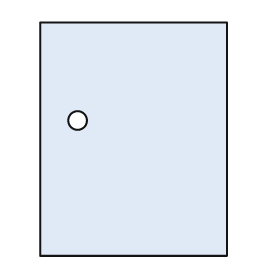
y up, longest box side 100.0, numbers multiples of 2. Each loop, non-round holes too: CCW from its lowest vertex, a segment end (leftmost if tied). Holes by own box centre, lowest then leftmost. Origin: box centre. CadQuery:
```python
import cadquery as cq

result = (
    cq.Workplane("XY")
    .moveTo(-40.0, -50.0)
    .lineTo(40.0, -50.0)
    .lineTo(40.0, 50.0)
    .lineTo(-40.0, 50.0)
    .close()
    .moveTo(-24.0, 8.0)
    .circle(4.0)
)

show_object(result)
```